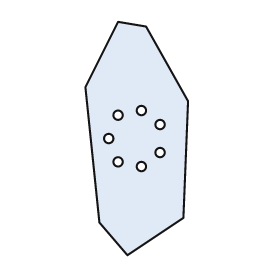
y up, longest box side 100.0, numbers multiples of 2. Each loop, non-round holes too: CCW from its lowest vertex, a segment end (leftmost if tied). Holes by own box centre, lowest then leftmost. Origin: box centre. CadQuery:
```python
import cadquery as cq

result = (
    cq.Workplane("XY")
    .moveTo(-4.0, -50.0)
    .lineTo(20.0, -34.0)
    .lineTo(22.0, 16.0)
    .lineTo(4.0, 48.0)
    .lineTo(-8.0, 50.0)
    .lineTo(-22.0, 22.0)
    .lineTo(-16.0, -36.0)
    .close()
    .moveTo(2.0, -12.0)
    .circle(2.0)
    .moveTo(-8.0, -10.0)
    .circle(2.0)
    .moveTo(10.0, -6.0)
    .circle(2.0)
    .moveTo(-12.0, 0.0)
    .circle(2.0)
    .moveTo(10.0, 6.0)
    .circle(2.0)
    .moveTo(-8.0, 10.0)
    .circle(2.0)
    .moveTo(2.0, 12.0)
    .circle(2.0)
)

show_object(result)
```